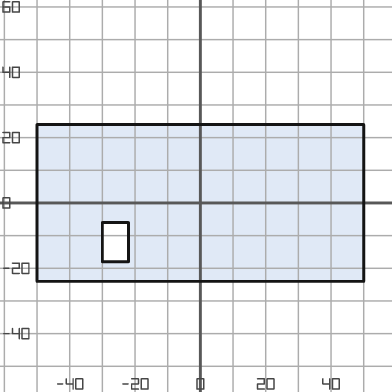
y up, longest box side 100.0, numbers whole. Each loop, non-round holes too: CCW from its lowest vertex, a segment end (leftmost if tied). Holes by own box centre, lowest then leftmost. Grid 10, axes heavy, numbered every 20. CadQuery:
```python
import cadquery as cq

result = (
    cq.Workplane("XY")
    .moveTo(-50.0, -24.0)
    .lineTo(50.0, -24.0)
    .lineTo(50.0, 24.0)
    .lineTo(-50.0, 24.0)
    .close()
    .moveTo(-30.0, -18.0)
    .lineTo(-22.0, -18.0)
    .lineTo(-22.0, -6.0)
    .lineTo(-30.0, -6.0)
    .close()
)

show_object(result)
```